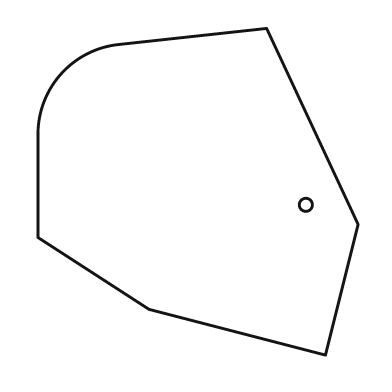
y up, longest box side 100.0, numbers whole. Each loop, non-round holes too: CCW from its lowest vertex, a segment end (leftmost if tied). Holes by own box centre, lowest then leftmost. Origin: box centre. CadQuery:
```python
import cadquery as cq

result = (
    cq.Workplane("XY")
    .moveTo(39.0, -50.0)
    .lineTo(49.0, -10.0)
    .lineTo(21.0, 50.0)
    .lineTo(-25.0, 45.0)
    .threePointArc((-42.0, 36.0), (-49.0, 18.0))
    .lineTo(-49.0, -14.0)
    .lineTo(-15.0, -36.0)
    .close()
    .moveTo(33.0, -4.0)
    .circle(2.0)
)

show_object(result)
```